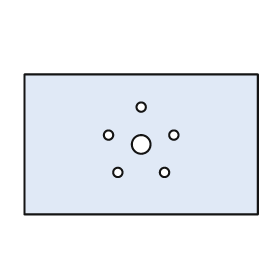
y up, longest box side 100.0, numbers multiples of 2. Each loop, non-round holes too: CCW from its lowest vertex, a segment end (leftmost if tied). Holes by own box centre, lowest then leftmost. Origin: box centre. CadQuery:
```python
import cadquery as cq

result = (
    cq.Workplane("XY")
    .moveTo(-50.0, -30.0)
    .lineTo(50.0, -30.0)
    .lineTo(50.0, 30.0)
    .lineTo(-50.0, 30.0)
    .close()
    .moveTo(-10.0, -12.0)
    .circle(2.0)
    .moveTo(10.0, -12.0)
    .circle(2.0)
    .moveTo(0.0, 0.0)
    .circle(4.0)
    .moveTo(-14.0, 4.0)
    .circle(2.0)
    .moveTo(14.0, 4.0)
    .circle(2.0)
    .moveTo(0.0, 16.0)
    .circle(2.0)
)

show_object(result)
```